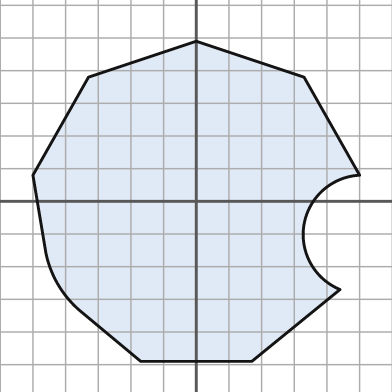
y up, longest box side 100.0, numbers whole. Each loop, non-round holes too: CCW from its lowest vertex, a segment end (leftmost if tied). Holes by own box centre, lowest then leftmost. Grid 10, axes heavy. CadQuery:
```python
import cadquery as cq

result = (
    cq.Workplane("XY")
    .moveTo(-17.0, -49.0)
    .lineTo(17.0, -49.0)
    .lineTo(44.0, -27.0)
    .threePointArc((33.0, -7.0), (50.0, 8.0))
    .lineTo(33.0, 38.0)
    .lineTo(0.0, 49.0)
    .lineTo(-33.0, 38.0)
    .lineTo(-50.0, 8.0)
    .lineTo(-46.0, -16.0)
    .threePointArc((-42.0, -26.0), (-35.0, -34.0))
    .close()
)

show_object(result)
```